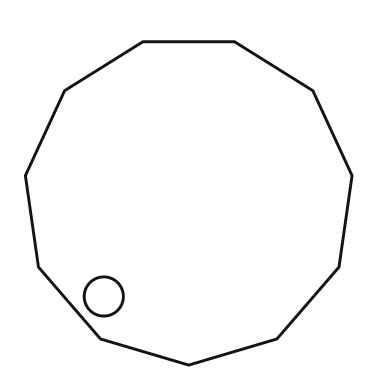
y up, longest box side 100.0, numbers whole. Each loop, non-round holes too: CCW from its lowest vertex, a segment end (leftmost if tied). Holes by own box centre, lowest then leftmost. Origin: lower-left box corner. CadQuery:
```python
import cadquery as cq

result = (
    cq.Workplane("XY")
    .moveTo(50.0, 0.0)
    .lineTo(77.0, 8.0)
    .lineTo(96.0, 30.0)
    .lineTo(100.0, 58.0)
    .lineTo(88.0, 84.0)
    .lineTo(64.0, 99.0)
    .lineTo(36.0, 99.0)
    .lineTo(12.0, 84.0)
    .lineTo(0.0, 58.0)
    .lineTo(4.0, 30.0)
    .lineTo(23.0, 8.0)
    .close()
    .moveTo(24.0, 21.0)
    .circle(6.0)
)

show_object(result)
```